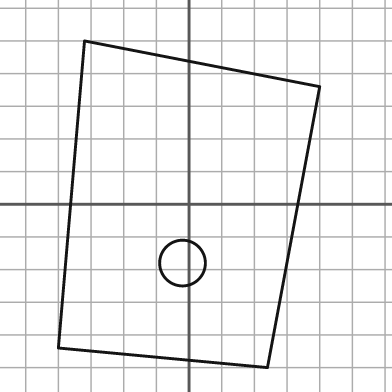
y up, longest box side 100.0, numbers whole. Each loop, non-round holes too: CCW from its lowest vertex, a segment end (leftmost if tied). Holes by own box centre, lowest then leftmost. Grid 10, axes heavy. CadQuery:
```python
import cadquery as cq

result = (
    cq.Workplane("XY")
    .moveTo(24.0, -50.0)
    .lineTo(40.0, 36.0)
    .lineTo(-32.0, 50.0)
    .lineTo(-40.0, -44.0)
    .close()
    .moveTo(-2.0, -18.0)
    .circle(7.0)
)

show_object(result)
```